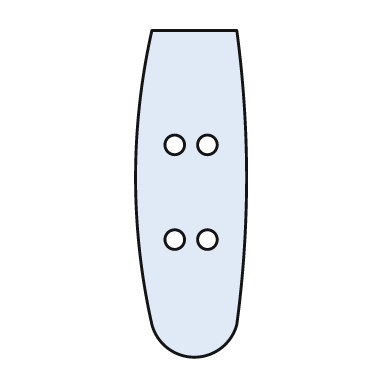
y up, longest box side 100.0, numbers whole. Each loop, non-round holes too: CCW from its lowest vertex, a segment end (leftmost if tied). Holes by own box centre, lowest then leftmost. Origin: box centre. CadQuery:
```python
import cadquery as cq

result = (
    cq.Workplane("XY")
    .moveTo(-12.0, -40.0)
    .threePointArc((1.0, -50.0), (14.0, -40.0))
    .threePointArc((17.0, 5.0), (14.0, 50.0))
    .lineTo(-12.0, 50.0)
    .threePointArc((-17.0, 5.0), (-12.0, -40.0))
    .close()
    .moveTo(-5.0, -14.0)
    .circle(3.0)
    .moveTo(5.0, -14.0)
    .circle(3.0)
    .moveTo(-5.0, 15.0)
    .circle(3.0)
    .moveTo(5.0, 15.0)
    .circle(3.0)
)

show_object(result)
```